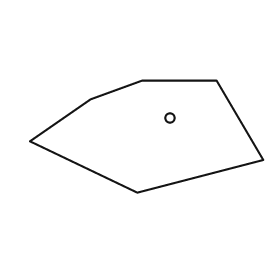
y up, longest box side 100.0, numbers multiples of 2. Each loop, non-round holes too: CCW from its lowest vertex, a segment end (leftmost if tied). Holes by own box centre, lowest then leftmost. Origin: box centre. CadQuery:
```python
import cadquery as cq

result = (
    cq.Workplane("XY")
    .moveTo(-4.0, -24.0)
    .lineTo(50.0, -10.0)
    .lineTo(30.0, 24.0)
    .lineTo(-2.0, 24.0)
    .lineTo(-24.0, 16.0)
    .lineTo(-50.0, -2.0)
    .close()
    .moveTo(10.0, 8.0)
    .circle(2.0)
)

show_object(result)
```